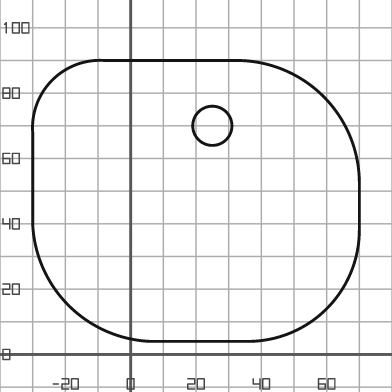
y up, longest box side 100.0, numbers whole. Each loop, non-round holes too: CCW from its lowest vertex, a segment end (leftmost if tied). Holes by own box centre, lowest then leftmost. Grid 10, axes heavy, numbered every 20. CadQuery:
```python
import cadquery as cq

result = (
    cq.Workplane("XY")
    .moveTo(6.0, 4.0)
    .lineTo(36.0, 4.0)
    .threePointArc((60.0, 14.0), (70.0, 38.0))
    .lineTo(70.0, 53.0)
    .threePointArc((59.0, 79.0), (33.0, 90.0))
    .lineTo(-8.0, 90.0)
    .threePointArc((-24.0, 84.0), (-30.0, 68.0))
    .lineTo(-30.0, 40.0)
    .threePointArc((-19.0, 15.0), (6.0, 4.0))
    .close()
    .moveTo(25.0, 70.0)
    .circle(6.0)
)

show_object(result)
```